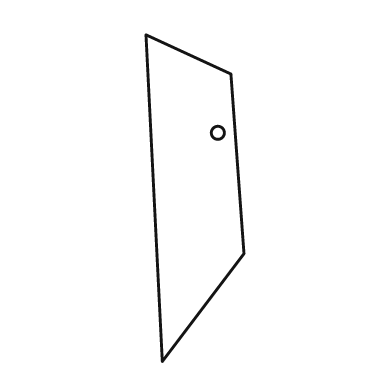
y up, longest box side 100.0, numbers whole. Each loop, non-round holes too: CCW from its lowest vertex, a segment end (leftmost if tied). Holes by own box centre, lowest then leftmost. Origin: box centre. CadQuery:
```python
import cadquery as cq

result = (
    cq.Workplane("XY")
    .moveTo(-10.0, -50.0)
    .lineTo(15.0, -17.0)
    .lineTo(11.0, 38.0)
    .lineTo(-15.0, 50.0)
    .close()
    .moveTo(7.0, 20.0)
    .circle(2.0)
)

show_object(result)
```